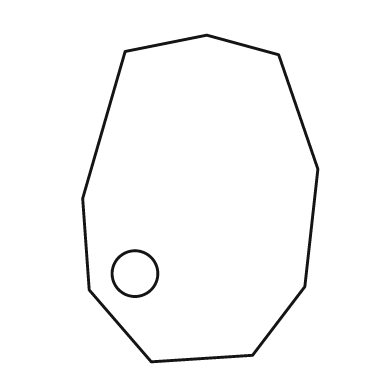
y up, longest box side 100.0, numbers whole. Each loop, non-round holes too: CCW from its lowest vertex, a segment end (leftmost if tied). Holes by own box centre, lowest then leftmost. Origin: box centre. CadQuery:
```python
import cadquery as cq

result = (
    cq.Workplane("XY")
    .moveTo(-15.0, -50.0)
    .lineTo(16.0, -48.0)
    .lineTo(32.0, -27.0)
    .lineTo(36.0, 9.0)
    .lineTo(24.0, 44.0)
    .lineTo(2.0, 50.0)
    .lineTo(-23.0, 45.0)
    .lineTo(-36.0, 0.0)
    .lineTo(-34.0, -28.0)
    .close()
    .moveTo(-20.0, -23.0)
    .circle(7.0)
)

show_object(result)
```